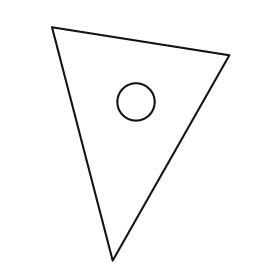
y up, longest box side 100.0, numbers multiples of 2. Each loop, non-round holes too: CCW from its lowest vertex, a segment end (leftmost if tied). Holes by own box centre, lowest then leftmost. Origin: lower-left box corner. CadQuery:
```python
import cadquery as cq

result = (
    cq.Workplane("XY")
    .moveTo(26.0, 0.0)
    .lineTo(76.0, 88.0)
    .lineTo(0.0, 100.0)
    .close()
    .moveTo(36.0, 68.0)
    .circle(8.0)
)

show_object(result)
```